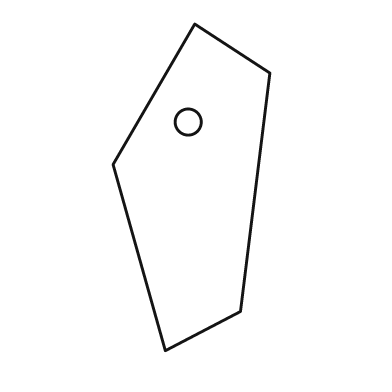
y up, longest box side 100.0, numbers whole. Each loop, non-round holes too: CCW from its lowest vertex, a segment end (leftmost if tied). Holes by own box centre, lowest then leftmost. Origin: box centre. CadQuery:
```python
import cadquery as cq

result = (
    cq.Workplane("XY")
    .moveTo(-8.0, -50.0)
    .lineTo(15.0, -38.0)
    .lineTo(24.0, 35.0)
    .lineTo(1.0, 50.0)
    .lineTo(-24.0, 7.0)
    .close()
    .moveTo(-1.0, 20.0)
    .circle(4.0)
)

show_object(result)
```